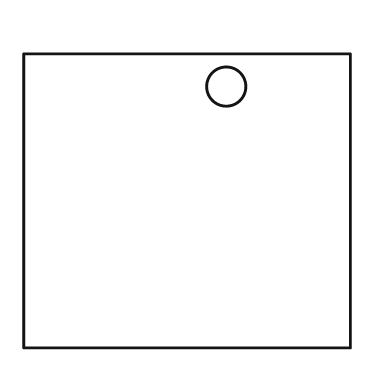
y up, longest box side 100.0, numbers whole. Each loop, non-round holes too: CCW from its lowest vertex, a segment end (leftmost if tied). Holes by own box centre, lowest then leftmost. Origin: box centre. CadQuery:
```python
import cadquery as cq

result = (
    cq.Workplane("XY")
    .moveTo(-50.0, -45.0)
    .lineTo(50.0, -45.0)
    .lineTo(50.0, 45.0)
    .lineTo(-50.0, 45.0)
    .close()
    .moveTo(12.0, 35.0)
    .circle(6.0)
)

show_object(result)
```